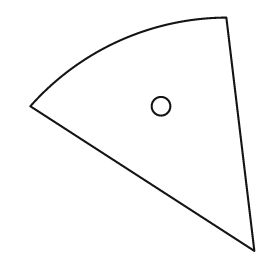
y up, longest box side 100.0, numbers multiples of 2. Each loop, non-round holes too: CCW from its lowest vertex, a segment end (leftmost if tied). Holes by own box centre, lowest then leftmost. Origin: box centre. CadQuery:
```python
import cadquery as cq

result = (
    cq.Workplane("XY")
    .moveTo(48.0, -50.0)
    .lineTo(36.0, 50.0)
    .threePointArc((-10.0, 40.0), (-48.0, 12.0))
    .close()
    .moveTo(8.0, 12.0)
    .circle(4.0)
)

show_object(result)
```